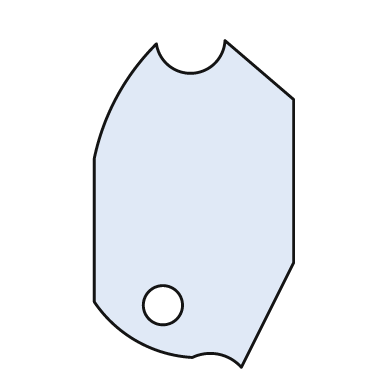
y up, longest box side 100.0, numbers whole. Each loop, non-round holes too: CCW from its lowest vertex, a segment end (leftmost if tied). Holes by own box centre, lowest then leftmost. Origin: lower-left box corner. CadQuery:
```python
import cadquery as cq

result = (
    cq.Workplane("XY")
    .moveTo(45.0, 0.0)
    .lineTo(61.0, 32.0)
    .lineTo(61.0, 82.0)
    .lineTo(40.0, 100.0)
    .threePointArc((30.0, 90.0), (19.0, 99.0))
    .threePointArc((7.0, 83.0), (0.0, 64.0))
    .lineTo(0.0, 20.0)
    .threePointArc((13.0, 8.0), (30.0, 3.0))
    .threePointArc((38.0, 4.0), (45.0, 0.0))
    .close()
    .moveTo(21.0, 19.0)
    .circle(6.0)
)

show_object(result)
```